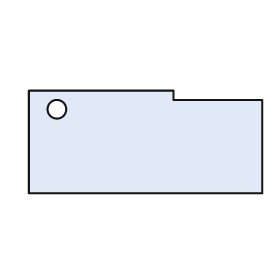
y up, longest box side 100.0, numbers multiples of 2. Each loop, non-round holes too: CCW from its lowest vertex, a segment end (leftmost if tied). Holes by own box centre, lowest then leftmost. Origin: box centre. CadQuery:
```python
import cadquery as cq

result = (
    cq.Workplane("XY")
    .moveTo(-50.0, -22.0)
    .lineTo(50.0, -22.0)
    .lineTo(50.0, 18.0)
    .lineTo(12.0, 18.0)
    .lineTo(12.0, 22.0)
    .lineTo(-50.0, 22.0)
    .close()
    .moveTo(-38.0, 14.0)
    .circle(4.0)
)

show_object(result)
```